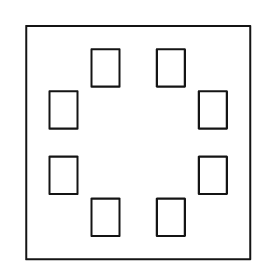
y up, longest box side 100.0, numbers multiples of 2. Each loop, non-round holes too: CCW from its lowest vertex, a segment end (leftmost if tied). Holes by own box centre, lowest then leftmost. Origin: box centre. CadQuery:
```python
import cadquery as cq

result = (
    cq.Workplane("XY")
    .moveTo(-48.0, -50.0)
    .lineTo(48.0, -50.0)
    .lineTo(48.0, 50.0)
    .lineTo(-48.0, 50.0)
    .close()
    .moveTo(-20.0, -40.0)
    .lineTo(-8.0, -40.0)
    .lineTo(-8.0, -24.0)
    .lineTo(-20.0, -24.0)
    .close()
    .moveTo(8.0, -40.0)
    .lineTo(20.0, -40.0)
    .lineTo(20.0, -24.0)
    .lineTo(8.0, -24.0)
    .close()
    .moveTo(-38.0, -22.0)
    .lineTo(-26.0, -22.0)
    .lineTo(-26.0, -6.0)
    .lineTo(-38.0, -6.0)
    .close()
    .moveTo(26.0, -22.0)
    .lineTo(38.0, -22.0)
    .lineTo(38.0, -6.0)
    .lineTo(26.0, -6.0)
    .close()
    .moveTo(-38.0, 6.0)
    .lineTo(-26.0, 6.0)
    .lineTo(-26.0, 22.0)
    .lineTo(-38.0, 22.0)
    .close()
    .moveTo(26.0, 6.0)
    .lineTo(38.0, 6.0)
    .lineTo(38.0, 22.0)
    .lineTo(26.0, 22.0)
    .close()
    .moveTo(-20.0, 24.0)
    .lineTo(-8.0, 24.0)
    .lineTo(-8.0, 40.0)
    .lineTo(-20.0, 40.0)
    .close()
    .moveTo(8.0, 24.0)
    .lineTo(20.0, 24.0)
    .lineTo(20.0, 40.0)
    .lineTo(8.0, 40.0)
    .close()
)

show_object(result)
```